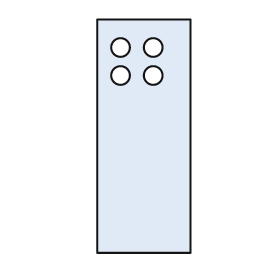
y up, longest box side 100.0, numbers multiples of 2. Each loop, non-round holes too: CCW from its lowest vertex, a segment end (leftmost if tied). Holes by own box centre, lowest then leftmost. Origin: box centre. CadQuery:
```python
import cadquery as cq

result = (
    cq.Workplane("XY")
    .moveTo(-20.0, -50.0)
    .lineTo(20.0, -50.0)
    .lineTo(20.0, 50.0)
    .lineTo(-20.0, 50.0)
    .close()
    .moveTo(-10.0, 26.0)
    .circle(4.0)
    .moveTo(4.0, 26.0)
    .circle(4.0)
    .moveTo(-10.0, 38.0)
    .circle(4.0)
    .moveTo(4.0, 38.0)
    .circle(4.0)
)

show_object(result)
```